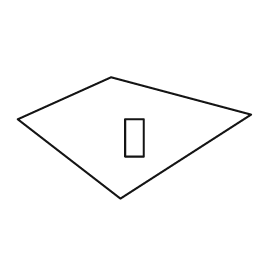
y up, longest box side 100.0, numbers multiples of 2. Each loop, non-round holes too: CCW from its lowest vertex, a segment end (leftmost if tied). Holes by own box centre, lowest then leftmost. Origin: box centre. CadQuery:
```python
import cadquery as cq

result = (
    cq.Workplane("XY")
    .moveTo(-6.0, -26.0)
    .lineTo(50.0, 10.0)
    .lineTo(-10.0, 26.0)
    .lineTo(-50.0, 8.0)
    .close()
    .moveTo(-4.0, -8.0)
    .lineTo(4.0, -8.0)
    .lineTo(4.0, 8.0)
    .lineTo(-4.0, 8.0)
    .close()
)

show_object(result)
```